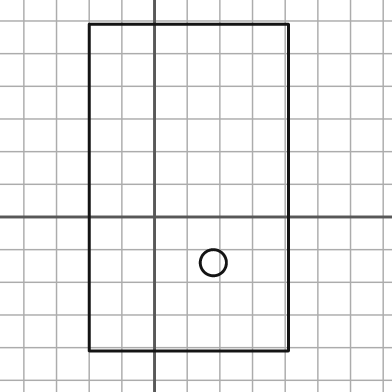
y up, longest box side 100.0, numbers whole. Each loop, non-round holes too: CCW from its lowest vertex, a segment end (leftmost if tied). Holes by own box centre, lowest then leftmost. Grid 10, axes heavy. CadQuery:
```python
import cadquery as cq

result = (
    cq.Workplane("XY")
    .moveTo(-20.0, -41.0)
    .lineTo(41.0, -41.0)
    .lineTo(41.0, 59.0)
    .lineTo(-20.0, 59.0)
    .close()
    .moveTo(18.0, -14.0)
    .circle(4.0)
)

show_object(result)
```